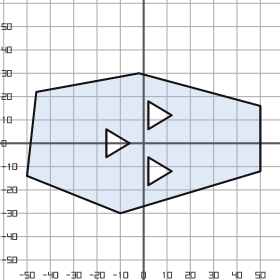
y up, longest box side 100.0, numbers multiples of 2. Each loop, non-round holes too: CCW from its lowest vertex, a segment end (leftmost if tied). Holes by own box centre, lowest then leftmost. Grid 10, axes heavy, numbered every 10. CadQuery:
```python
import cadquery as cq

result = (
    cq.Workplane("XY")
    .moveTo(-10.0, -30.0)
    .lineTo(50.0, -12.0)
    .lineTo(50.0, 16.0)
    .lineTo(-2.0, 30.0)
    .lineTo(-46.0, 22.0)
    .lineTo(-50.0, -14.0)
    .close()
    .moveTo(2.0, -18.0)
    .lineTo(12.0, -12.0)
    .lineTo(2.0, -6.0)
    .close()
    .moveTo(-16.0, -6.0)
    .lineTo(-6.0, 0.0)
    .lineTo(-16.0, 6.0)
    .close()
    .moveTo(2.0, 6.0)
    .lineTo(12.0, 12.0)
    .lineTo(2.0, 18.0)
    .close()
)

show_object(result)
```